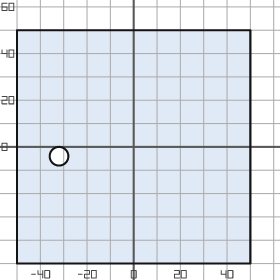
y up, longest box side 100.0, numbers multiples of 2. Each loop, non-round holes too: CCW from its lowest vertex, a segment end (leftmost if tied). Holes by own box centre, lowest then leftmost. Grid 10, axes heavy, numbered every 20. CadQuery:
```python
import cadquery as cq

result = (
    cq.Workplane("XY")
    .moveTo(-50.0, -50.0)
    .lineTo(50.0, -50.0)
    .lineTo(50.0, 50.0)
    .lineTo(-50.0, 50.0)
    .close()
    .moveTo(-32.0, -4.0)
    .circle(4.0)
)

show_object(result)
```